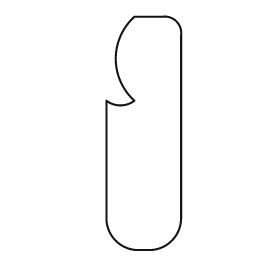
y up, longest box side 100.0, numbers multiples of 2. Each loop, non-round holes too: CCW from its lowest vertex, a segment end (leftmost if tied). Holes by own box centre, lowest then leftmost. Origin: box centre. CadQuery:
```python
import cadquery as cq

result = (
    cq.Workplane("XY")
    .moveTo(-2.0, -50.0)
    .lineTo(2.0, -50.0)
    .threePointArc((12.0, -46.0), (16.0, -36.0))
    .lineTo(16.0, 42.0)
    .threePointArc((14.0, 48.0), (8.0, 50.0))
    .lineTo(-4.0, 50.0)
    .threePointArc((-12.0, 32.0), (-4.0, 14.0))
    .threePointArc((-10.0, 12.0), (-16.0, 14.0))
    .lineTo(-16.0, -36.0)
    .threePointArc((-12.0, -46.0), (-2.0, -50.0))
    .close()
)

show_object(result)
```